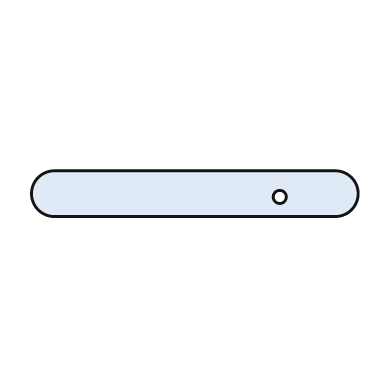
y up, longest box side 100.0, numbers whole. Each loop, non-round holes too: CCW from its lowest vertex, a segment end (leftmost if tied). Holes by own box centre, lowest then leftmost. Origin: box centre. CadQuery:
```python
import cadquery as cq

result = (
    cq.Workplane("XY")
    .moveTo(-43.0, -7.0)
    .lineTo(43.0, -7.0)
    .threePointArc((50.0, 0.0), (43.0, 7.0))
    .lineTo(-43.0, 7.0)
    .threePointArc((-50.0, 0.0), (-43.0, -7.0))
    .close()
    .moveTo(26.0, -1.0)
    .circle(2.0)
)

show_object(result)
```